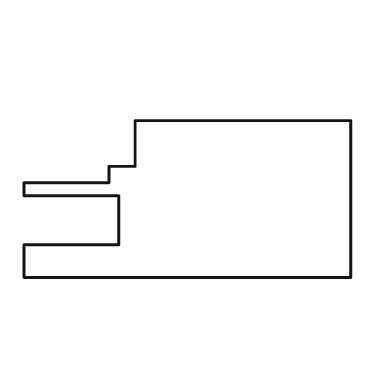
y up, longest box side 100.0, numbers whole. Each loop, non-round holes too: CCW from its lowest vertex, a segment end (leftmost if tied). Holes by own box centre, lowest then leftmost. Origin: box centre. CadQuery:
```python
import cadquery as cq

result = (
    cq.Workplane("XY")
    .moveTo(-50.0, -24.0)
    .lineTo(50.0, -24.0)
    .lineTo(50.0, 24.0)
    .lineTo(-16.0, 24.0)
    .lineTo(-16.0, 10.0)
    .lineTo(-24.0, 10.0)
    .lineTo(-24.0, 5.0)
    .lineTo(-50.0, 5.0)
    .lineTo(-50.0, 1.0)
    .lineTo(-21.0, 1.0)
    .lineTo(-21.0, -14.0)
    .lineTo(-50.0, -14.0)
    .close()
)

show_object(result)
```